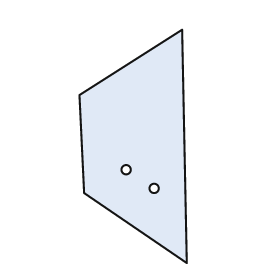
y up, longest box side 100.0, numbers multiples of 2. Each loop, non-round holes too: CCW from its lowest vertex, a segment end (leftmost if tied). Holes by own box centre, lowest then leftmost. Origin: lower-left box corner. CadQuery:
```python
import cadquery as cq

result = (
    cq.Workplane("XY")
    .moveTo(46.0, 0.0)
    .lineTo(44.0, 100.0)
    .lineTo(0.0, 72.0)
    .lineTo(2.0, 30.0)
    .close()
    .moveTo(32.0, 32.0)
    .circle(2.0)
    .moveTo(20.0, 40.0)
    .circle(2.0)
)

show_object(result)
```